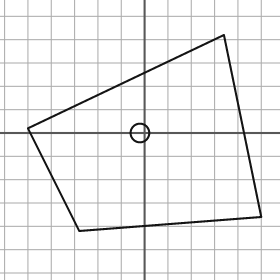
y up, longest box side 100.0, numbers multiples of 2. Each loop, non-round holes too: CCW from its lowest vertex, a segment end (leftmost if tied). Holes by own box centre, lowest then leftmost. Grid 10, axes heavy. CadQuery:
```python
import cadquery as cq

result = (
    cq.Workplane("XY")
    .moveTo(-28.0, -42.0)
    .lineTo(50.0, -36.0)
    .lineTo(34.0, 42.0)
    .lineTo(-50.0, 2.0)
    .close()
    .moveTo(-2.0, 0.0)
    .circle(4.0)
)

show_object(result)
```